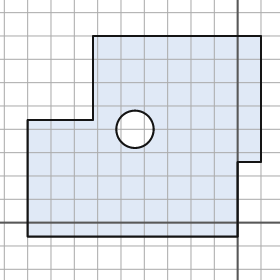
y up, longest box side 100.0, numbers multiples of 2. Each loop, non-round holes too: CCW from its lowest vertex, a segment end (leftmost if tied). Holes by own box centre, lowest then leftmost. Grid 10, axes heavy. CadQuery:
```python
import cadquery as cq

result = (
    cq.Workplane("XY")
    .moveTo(-90.0, -6.0)
    .lineTo(0.0, -6.0)
    .lineTo(0.0, 26.0)
    .lineTo(10.0, 26.0)
    .lineTo(10.0, 80.0)
    .lineTo(-62.0, 80.0)
    .lineTo(-62.0, 44.0)
    .lineTo(-90.0, 44.0)
    .close()
    .moveTo(-44.0, 40.0)
    .circle(8.0)
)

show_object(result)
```